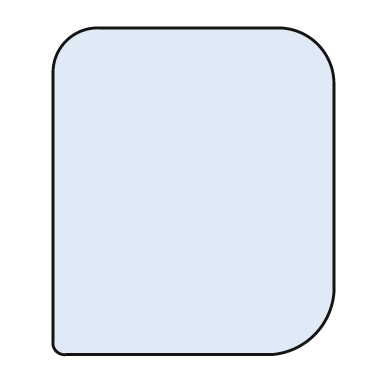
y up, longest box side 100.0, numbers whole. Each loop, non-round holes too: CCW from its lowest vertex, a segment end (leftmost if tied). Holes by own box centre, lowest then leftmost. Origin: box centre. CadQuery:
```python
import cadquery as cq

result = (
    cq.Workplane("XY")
    .moveTo(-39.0, -50.0)
    .lineTo(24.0, -50.0)
    .threePointArc((37.0, -44.0), (43.0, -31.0))
    .lineTo(43.0, 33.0)
    .threePointArc((38.0, 45.0), (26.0, 50.0))
    .lineTo(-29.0, 50.0)
    .threePointArc((-39.0, 46.0), (-43.0, 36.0))
    .lineTo(-43.0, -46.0)
    .threePointArc((-42.0, -49.0), (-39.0, -50.0))
    .close()
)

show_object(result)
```